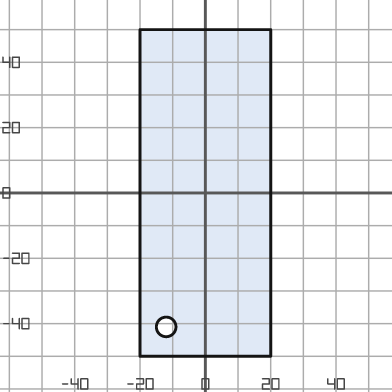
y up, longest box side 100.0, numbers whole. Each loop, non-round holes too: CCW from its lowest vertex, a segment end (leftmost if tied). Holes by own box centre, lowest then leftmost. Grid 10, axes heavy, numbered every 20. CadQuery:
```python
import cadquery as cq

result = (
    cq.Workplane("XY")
    .moveTo(-20.0, -50.0)
    .lineTo(20.0, -50.0)
    .lineTo(20.0, 50.0)
    .lineTo(-20.0, 50.0)
    .close()
    .moveTo(-12.0, -41.0)
    .circle(3.0)
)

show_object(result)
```